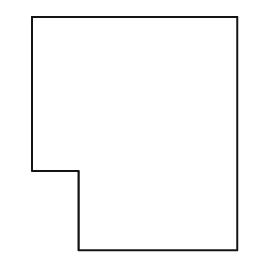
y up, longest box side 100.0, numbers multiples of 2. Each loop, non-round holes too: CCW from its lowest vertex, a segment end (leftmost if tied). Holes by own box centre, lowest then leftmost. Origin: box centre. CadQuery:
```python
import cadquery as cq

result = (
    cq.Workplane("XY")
    .moveTo(-24.0, -50.0)
    .lineTo(44.0, -50.0)
    .lineTo(44.0, 50.0)
    .lineTo(-44.0, 50.0)
    .lineTo(-44.0, -16.0)
    .lineTo(-24.0, -16.0)
    .close()
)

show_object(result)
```